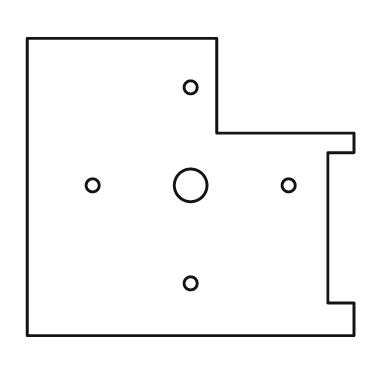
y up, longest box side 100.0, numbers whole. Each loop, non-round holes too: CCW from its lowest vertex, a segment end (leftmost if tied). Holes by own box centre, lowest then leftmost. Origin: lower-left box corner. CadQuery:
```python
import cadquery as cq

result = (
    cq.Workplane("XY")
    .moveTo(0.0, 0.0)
    .lineTo(100.0, 0.0)
    .lineTo(100.0, 10.0)
    .lineTo(92.0, 10.0)
    .lineTo(92.0, 56.0)
    .lineTo(100.0, 56.0)
    .lineTo(100.0, 62.0)
    .lineTo(58.0, 62.0)
    .lineTo(58.0, 91.0)
    .lineTo(0.0, 91.0)
    .close()
    .moveTo(50.0, 16.0)
    .circle(2.0)
    .moveTo(20.0, 46.0)
    .circle(2.0)
    .moveTo(50.0, 46.0)
    .circle(5.0)
    .moveTo(80.0, 46.0)
    .circle(2.0)
    .moveTo(50.0, 76.0)
    .circle(2.0)
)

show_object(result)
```